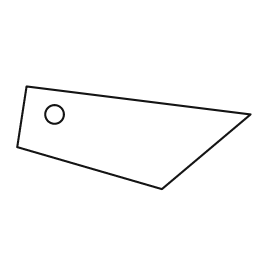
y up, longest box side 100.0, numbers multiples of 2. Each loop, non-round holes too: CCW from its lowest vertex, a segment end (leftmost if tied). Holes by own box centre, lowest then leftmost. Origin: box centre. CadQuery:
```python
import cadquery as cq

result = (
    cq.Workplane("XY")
    .moveTo(12.0, -22.0)
    .lineTo(50.0, 10.0)
    .lineTo(-46.0, 22.0)
    .lineTo(-50.0, -4.0)
    .close()
    .moveTo(-34.0, 10.0)
    .circle(4.0)
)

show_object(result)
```